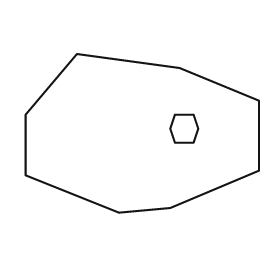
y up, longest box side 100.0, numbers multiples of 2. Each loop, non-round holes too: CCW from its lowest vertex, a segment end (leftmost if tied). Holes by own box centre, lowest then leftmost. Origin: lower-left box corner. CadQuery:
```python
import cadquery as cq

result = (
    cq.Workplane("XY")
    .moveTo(40.0, 0.0)
    .lineTo(62.0, 2.0)
    .lineTo(100.0, 18.0)
    .lineTo(100.0, 48.0)
    .lineTo(66.0, 62.0)
    .lineTo(22.0, 68.0)
    .lineTo(0.0, 42.0)
    .lineTo(0.0, 16.0)
    .close()
    .moveTo(64.0, 30.0)
    .lineTo(72.0, 30.0)
    .lineTo(74.0, 36.0)
    .lineTo(72.0, 42.0)
    .lineTo(64.0, 42.0)
    .lineTo(62.0, 36.0)
    .close()
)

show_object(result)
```